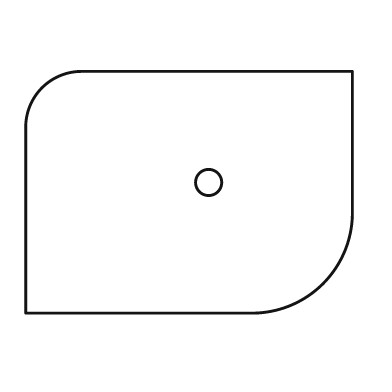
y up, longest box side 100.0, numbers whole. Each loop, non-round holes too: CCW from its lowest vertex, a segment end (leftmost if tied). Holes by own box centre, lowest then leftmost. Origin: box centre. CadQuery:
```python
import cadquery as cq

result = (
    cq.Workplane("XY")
    .moveTo(-50.0, -37.0)
    .lineTo(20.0, -37.0)
    .threePointArc((41.0, -28.0), (50.0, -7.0))
    .lineTo(50.0, 37.0)
    .lineTo(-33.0, 37.0)
    .threePointArc((-45.0, 32.0), (-50.0, 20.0))
    .close()
    .moveTo(6.0, 3.0)
    .circle(4.0)
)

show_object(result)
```